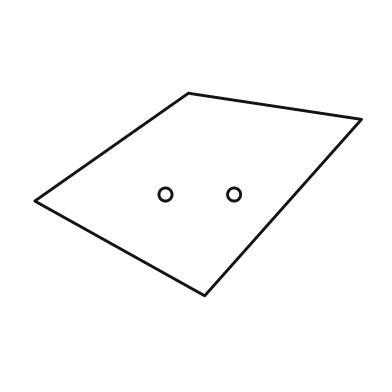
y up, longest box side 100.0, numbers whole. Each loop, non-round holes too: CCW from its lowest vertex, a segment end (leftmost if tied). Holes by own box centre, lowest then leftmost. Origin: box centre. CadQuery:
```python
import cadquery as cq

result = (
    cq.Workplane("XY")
    .moveTo(2.0, -31.0)
    .lineTo(50.0, 23.0)
    .lineTo(-3.0, 31.0)
    .lineTo(-50.0, -2.0)
    .close()
    .moveTo(-10.0, 0.0)
    .circle(2.0)
    .moveTo(11.0, 0.0)
    .circle(2.0)
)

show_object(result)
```